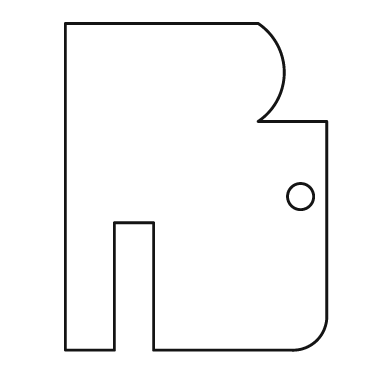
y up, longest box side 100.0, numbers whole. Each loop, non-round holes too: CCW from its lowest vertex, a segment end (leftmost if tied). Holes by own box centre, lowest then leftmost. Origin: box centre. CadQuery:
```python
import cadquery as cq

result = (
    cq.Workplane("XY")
    .moveTo(-40.0, -50.0)
    .lineTo(-25.0, -50.0)
    .lineTo(-25.0, -11.0)
    .lineTo(-13.0, -11.0)
    .lineTo(-13.0, -50.0)
    .lineTo(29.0, -50.0)
    .threePointArc((37.0, -47.0), (40.0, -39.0))
    .lineTo(40.0, 20.0)
    .lineTo(19.0, 20.0)
    .threePointArc((27.0, 35.0), (19.0, 50.0))
    .lineTo(-40.0, 50.0)
    .close()
    .moveTo(32.0, -3.0)
    .circle(4.0)
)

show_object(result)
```